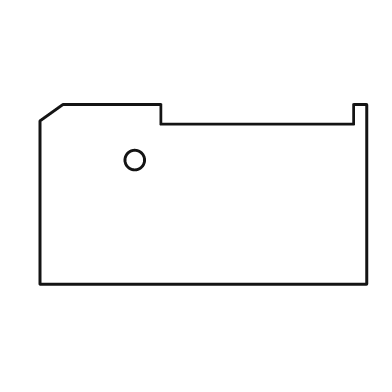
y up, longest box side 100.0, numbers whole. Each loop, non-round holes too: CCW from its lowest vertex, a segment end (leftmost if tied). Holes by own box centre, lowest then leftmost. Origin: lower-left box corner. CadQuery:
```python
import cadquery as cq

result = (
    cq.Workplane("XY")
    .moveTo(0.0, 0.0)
    .lineTo(100.0, 0.0)
    .lineTo(100.0, 55.0)
    .lineTo(96.0, 55.0)
    .lineTo(96.0, 49.0)
    .lineTo(37.0, 49.0)
    .lineTo(37.0, 55.0)
    .lineTo(7.0, 55.0)
    .lineTo(0.0, 50.0)
    .close()
    .moveTo(29.0, 38.0)
    .circle(3.0)
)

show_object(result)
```